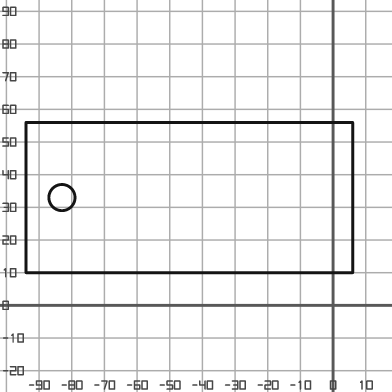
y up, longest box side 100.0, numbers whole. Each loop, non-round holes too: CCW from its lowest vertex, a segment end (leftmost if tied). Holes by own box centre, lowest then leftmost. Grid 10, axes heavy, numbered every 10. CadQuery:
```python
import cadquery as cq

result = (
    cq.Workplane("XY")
    .moveTo(-94.0, 10.0)
    .lineTo(6.0, 10.0)
    .lineTo(6.0, 56.0)
    .lineTo(-94.0, 56.0)
    .close()
    .moveTo(-83.0, 33.0)
    .circle(4.0)
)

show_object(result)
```